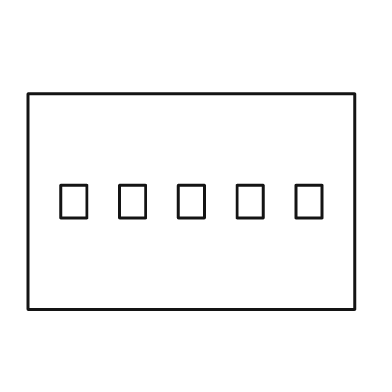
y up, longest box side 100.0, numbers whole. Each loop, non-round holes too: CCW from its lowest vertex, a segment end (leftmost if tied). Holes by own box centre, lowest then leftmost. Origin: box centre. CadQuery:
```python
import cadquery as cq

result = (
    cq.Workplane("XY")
    .moveTo(-50.0, -33.0)
    .lineTo(50.0, -33.0)
    .lineTo(50.0, 33.0)
    .lineTo(-50.0, 33.0)
    .close()
    .moveTo(-40.0, -5.0)
    .lineTo(-32.0, -5.0)
    .lineTo(-32.0, 5.0)
    .lineTo(-40.0, 5.0)
    .close()
    .moveTo(-22.0, -5.0)
    .lineTo(-14.0, -5.0)
    .lineTo(-14.0, 5.0)
    .lineTo(-22.0, 5.0)
    .close()
    .moveTo(-4.0, -5.0)
    .lineTo(4.0, -5.0)
    .lineTo(4.0, 5.0)
    .lineTo(-4.0, 5.0)
    .close()
    .moveTo(14.0, -5.0)
    .lineTo(22.0, -5.0)
    .lineTo(22.0, 5.0)
    .lineTo(14.0, 5.0)
    .close()
    .moveTo(32.0, -5.0)
    .lineTo(40.0, -5.0)
    .lineTo(40.0, 5.0)
    .lineTo(32.0, 5.0)
    .close()
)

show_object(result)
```